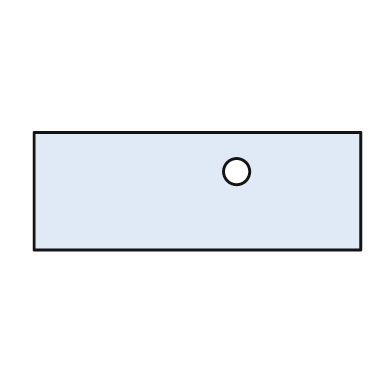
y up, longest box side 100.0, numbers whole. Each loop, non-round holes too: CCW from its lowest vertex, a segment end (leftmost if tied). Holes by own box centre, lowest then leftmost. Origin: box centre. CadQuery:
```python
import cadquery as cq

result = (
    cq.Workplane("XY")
    .moveTo(-50.0, -18.0)
    .lineTo(50.0, -18.0)
    .lineTo(50.0, 18.0)
    .lineTo(-50.0, 18.0)
    .close()
    .moveTo(12.0, 6.0)
    .circle(4.0)
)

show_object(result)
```